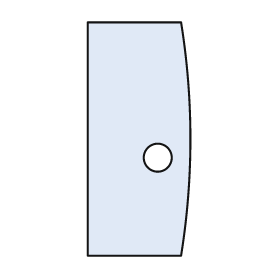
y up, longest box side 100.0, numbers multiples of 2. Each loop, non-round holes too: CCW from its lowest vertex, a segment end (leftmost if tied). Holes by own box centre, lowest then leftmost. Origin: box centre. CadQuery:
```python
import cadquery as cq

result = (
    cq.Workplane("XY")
    .moveTo(-22.0, -50.0)
    .lineTo(18.0, -50.0)
    .threePointArc((22.0, 0.0), (18.0, 50.0))
    .lineTo(-22.0, 50.0)
    .close()
    .moveTo(8.0, -8.0)
    .circle(6.0)
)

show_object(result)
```